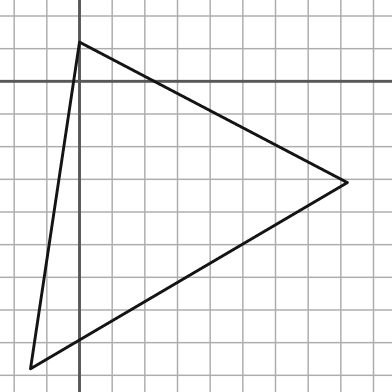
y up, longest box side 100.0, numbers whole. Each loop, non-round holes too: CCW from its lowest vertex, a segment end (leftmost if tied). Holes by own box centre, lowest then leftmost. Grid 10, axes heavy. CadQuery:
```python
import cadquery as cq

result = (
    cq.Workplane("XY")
    .moveTo(-15.0, -88.0)
    .lineTo(82.0, -31.0)
    .lineTo(0.0, 12.0)
    .close()
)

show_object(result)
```